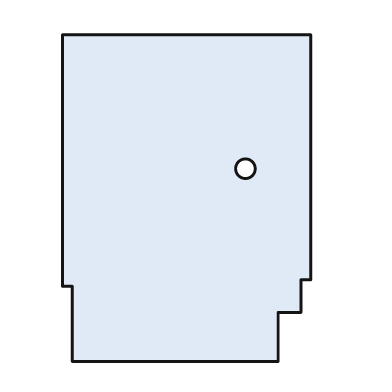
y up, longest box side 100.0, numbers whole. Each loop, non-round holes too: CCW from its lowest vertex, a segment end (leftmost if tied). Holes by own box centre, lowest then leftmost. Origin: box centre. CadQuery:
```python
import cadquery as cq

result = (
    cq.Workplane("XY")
    .moveTo(-35.0, -50.0)
    .lineTo(28.0, -50.0)
    .lineTo(28.0, -35.0)
    .lineTo(35.0, -35.0)
    .lineTo(35.0, -25.0)
    .lineTo(38.0, -25.0)
    .lineTo(38.0, 50.0)
    .lineTo(-38.0, 50.0)
    .lineTo(-38.0, -27.0)
    .lineTo(-35.0, -27.0)
    .close()
    .moveTo(18.0, 9.0)
    .circle(3.0)
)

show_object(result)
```